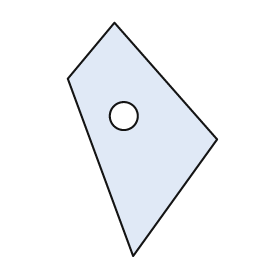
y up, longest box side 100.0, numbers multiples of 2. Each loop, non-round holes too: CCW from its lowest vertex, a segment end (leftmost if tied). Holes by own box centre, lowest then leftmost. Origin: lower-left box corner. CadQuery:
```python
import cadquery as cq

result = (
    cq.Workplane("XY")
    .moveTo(28.0, 0.0)
    .lineTo(64.0, 50.0)
    .lineTo(20.0, 100.0)
    .lineTo(0.0, 76.0)
    .close()
    .moveTo(24.0, 60.0)
    .circle(6.0)
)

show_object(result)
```